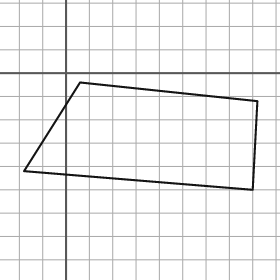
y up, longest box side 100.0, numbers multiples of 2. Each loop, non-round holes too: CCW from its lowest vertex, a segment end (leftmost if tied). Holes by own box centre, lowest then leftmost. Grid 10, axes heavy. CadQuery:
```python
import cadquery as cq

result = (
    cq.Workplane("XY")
    .moveTo(80.0, -50.0)
    .lineTo(82.0, -12.0)
    .lineTo(6.0, -4.0)
    .lineTo(-18.0, -42.0)
    .close()
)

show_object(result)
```